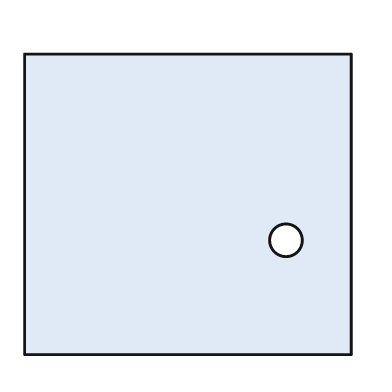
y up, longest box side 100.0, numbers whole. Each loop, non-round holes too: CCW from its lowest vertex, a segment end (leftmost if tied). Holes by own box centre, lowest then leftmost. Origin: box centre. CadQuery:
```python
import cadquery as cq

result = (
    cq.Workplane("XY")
    .moveTo(-50.0, -46.0)
    .lineTo(50.0, -46.0)
    .lineTo(50.0, 46.0)
    .lineTo(-50.0, 46.0)
    .close()
    .moveTo(30.0, -11.0)
    .circle(5.0)
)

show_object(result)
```